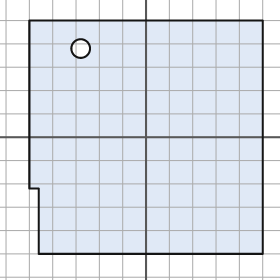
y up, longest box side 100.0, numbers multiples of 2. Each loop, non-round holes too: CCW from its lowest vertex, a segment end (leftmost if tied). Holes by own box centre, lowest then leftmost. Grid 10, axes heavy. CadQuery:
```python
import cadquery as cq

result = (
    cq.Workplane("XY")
    .moveTo(-46.0, -50.0)
    .lineTo(50.0, -50.0)
    .lineTo(50.0, 50.0)
    .lineTo(-50.0, 50.0)
    .lineTo(-50.0, -22.0)
    .lineTo(-46.0, -22.0)
    .close()
    .moveTo(-28.0, 38.0)
    .circle(4.0)
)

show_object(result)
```